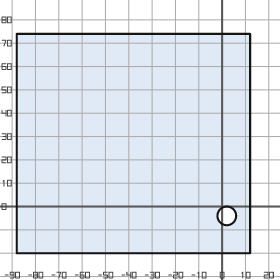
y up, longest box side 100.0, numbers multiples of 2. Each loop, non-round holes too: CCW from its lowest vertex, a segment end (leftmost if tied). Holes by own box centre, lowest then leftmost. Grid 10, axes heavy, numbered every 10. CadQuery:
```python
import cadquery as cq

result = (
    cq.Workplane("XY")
    .moveTo(-88.0, -20.0)
    .lineTo(12.0, -20.0)
    .lineTo(12.0, 74.0)
    .lineTo(-88.0, 74.0)
    .close()
    .moveTo(2.0, -4.0)
    .circle(4.0)
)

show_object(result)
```